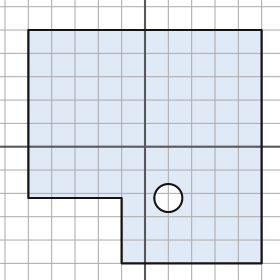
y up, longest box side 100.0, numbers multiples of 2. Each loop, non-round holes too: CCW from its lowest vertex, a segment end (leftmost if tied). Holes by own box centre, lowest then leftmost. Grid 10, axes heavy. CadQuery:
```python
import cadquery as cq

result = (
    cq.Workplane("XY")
    .moveTo(-10.0, -50.0)
    .lineTo(50.0, -50.0)
    .lineTo(50.0, 50.0)
    .lineTo(-50.0, 50.0)
    .lineTo(-50.0, -22.0)
    .lineTo(-10.0, -22.0)
    .close()
    .moveTo(10.0, -22.0)
    .circle(6.0)
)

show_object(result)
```